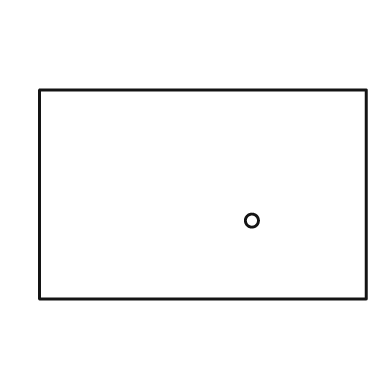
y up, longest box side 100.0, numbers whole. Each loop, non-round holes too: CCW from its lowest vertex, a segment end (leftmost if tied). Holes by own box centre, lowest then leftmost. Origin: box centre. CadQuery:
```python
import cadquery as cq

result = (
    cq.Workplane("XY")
    .moveTo(-50.0, -32.0)
    .lineTo(50.0, -32.0)
    .lineTo(50.0, 32.0)
    .lineTo(-50.0, 32.0)
    .close()
    .moveTo(15.0, -8.0)
    .circle(2.0)
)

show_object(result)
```